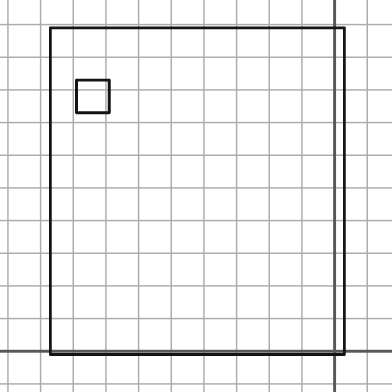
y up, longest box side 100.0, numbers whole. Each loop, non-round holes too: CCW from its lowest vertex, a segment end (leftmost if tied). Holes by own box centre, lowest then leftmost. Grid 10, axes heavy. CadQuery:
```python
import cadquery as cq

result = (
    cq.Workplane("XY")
    .moveTo(-87.0, -1.0)
    .lineTo(3.0, -1.0)
    .lineTo(3.0, 99.0)
    .lineTo(-87.0, 99.0)
    .close()
    .moveTo(-79.0, 73.0)
    .lineTo(-69.0, 73.0)
    .lineTo(-69.0, 83.0)
    .lineTo(-79.0, 83.0)
    .close()
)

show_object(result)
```